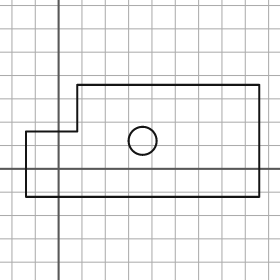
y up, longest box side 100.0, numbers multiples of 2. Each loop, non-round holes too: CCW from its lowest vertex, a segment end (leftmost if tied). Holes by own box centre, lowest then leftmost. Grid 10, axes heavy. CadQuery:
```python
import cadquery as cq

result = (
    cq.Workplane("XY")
    .moveTo(-14.0, -12.0)
    .lineTo(86.0, -12.0)
    .lineTo(86.0, 36.0)
    .lineTo(8.0, 36.0)
    .lineTo(8.0, 16.0)
    .lineTo(-14.0, 16.0)
    .close()
    .moveTo(36.0, 12.0)
    .circle(6.0)
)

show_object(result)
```